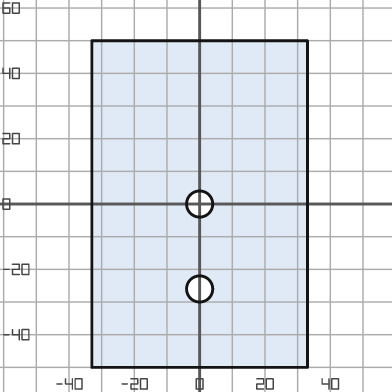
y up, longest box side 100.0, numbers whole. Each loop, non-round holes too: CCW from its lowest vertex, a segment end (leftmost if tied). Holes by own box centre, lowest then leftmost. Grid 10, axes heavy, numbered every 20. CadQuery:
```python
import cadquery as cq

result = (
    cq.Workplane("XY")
    .moveTo(-33.0, -50.0)
    .lineTo(33.0, -50.0)
    .lineTo(33.0, 50.0)
    .lineTo(-33.0, 50.0)
    .close()
    .moveTo(0.0, -26.0)
    .circle(4.0)
    .moveTo(0.0, 0.0)
    .circle(4.0)
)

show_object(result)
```